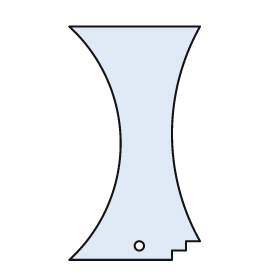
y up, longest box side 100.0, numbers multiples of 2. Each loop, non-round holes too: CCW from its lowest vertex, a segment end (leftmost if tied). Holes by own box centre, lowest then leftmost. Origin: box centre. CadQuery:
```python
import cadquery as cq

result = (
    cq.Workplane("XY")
    .moveTo(-28.0, -50.0)
    .lineTo(16.0, -50.0)
    .lineTo(16.0, -46.0)
    .lineTo(22.0, -46.0)
    .lineTo(22.0, -42.0)
    .lineTo(28.0, -42.0)
    .threePointArc((16.0, 4.0), (28.0, 50.0))
    .lineTo(-28.0, 50.0)
    .threePointArc((-6.0, 0.0), (-28.0, -50.0))
    .close()
    .moveTo(2.0, -44.0)
    .circle(2.0)
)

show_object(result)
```